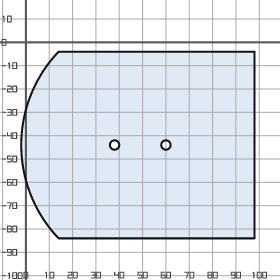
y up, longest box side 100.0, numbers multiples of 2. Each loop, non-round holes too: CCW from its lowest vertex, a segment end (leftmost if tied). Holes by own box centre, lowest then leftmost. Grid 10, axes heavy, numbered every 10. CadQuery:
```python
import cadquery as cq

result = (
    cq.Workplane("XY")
    .moveTo(14.0, -84.0)
    .lineTo(98.0, -84.0)
    .lineTo(98.0, -4.0)
    .lineTo(14.0, -4.0)
    .threePointArc((-2.0, -44.0), (14.0, -84.0))
    .close()
    .moveTo(38.0, -44.0)
    .circle(2.0)
    .moveTo(60.0, -44.0)
    .circle(2.0)
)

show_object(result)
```